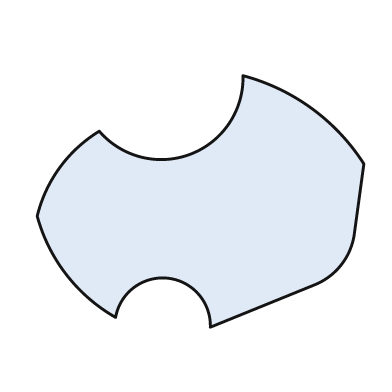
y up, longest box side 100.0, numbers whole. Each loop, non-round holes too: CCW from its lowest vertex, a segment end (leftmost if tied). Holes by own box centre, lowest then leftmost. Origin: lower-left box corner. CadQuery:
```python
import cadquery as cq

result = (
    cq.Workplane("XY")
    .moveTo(53.0, 0.0)
    .lineTo(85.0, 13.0)
    .threePointArc((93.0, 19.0), (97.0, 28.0))
    .lineTo(100.0, 50.0)
    .threePointArc((84.0, 67.0), (63.0, 77.0))
    .threePointArc((47.0, 53.0), (19.0, 60.0))
    .threePointArc((7.0, 49.0), (0.0, 34.0))
    .threePointArc((9.0, 16.0), (24.0, 3.0))
    .threePointArc((40.0, 15.0), (53.0, 0.0))
    .close()
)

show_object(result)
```